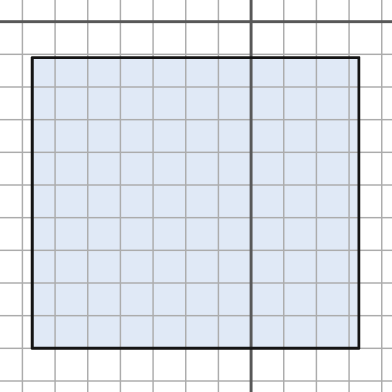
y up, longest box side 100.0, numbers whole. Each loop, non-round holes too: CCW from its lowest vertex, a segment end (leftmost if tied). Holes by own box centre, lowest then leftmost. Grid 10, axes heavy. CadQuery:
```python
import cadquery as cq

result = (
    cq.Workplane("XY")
    .moveTo(-67.0, -100.0)
    .lineTo(33.0, -100.0)
    .lineTo(33.0, -11.0)
    .lineTo(-67.0, -11.0)
    .close()
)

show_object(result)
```